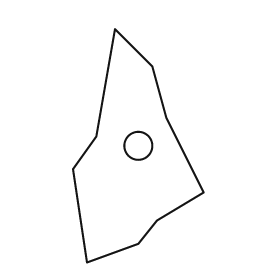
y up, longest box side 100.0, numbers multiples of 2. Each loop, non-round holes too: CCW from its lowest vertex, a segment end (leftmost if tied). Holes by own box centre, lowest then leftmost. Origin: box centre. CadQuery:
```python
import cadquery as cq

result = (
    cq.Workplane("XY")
    .moveTo(-22.0, -50.0)
    .lineTo(0.0, -42.0)
    .lineTo(8.0, -32.0)
    .lineTo(28.0, -20.0)
    .lineTo(12.0, 12.0)
    .lineTo(6.0, 34.0)
    .lineTo(-10.0, 50.0)
    .lineTo(-18.0, 4.0)
    .lineTo(-28.0, -10.0)
    .close()
    .moveTo(0.0, 0.0)
    .circle(6.0)
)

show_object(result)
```